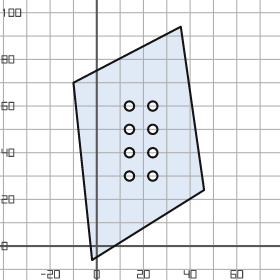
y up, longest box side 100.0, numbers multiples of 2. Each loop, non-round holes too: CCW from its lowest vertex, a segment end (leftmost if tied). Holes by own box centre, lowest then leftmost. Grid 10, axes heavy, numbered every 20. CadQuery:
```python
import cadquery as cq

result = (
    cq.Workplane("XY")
    .moveTo(-2.0, -6.0)
    .lineTo(46.0, 24.0)
    .lineTo(36.0, 94.0)
    .lineTo(-10.0, 70.0)
    .close()
    .moveTo(14.0, 30.0)
    .circle(2.0)
    .moveTo(24.0, 30.0)
    .circle(2.0)
    .moveTo(14.0, 40.0)
    .circle(2.0)
    .moveTo(24.0, 40.0)
    .circle(2.0)
    .moveTo(14.0, 50.0)
    .circle(2.0)
    .moveTo(24.0, 50.0)
    .circle(2.0)
    .moveTo(14.0, 60.0)
    .circle(2.0)
    .moveTo(24.0, 60.0)
    .circle(2.0)
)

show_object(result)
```